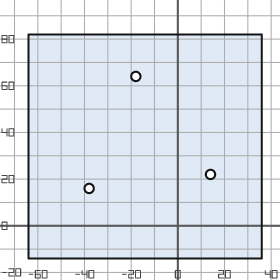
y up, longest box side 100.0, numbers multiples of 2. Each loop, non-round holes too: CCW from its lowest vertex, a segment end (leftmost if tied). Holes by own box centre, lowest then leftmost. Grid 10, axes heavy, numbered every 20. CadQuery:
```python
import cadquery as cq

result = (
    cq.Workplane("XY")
    .moveTo(-64.0, -14.0)
    .lineTo(36.0, -14.0)
    .lineTo(36.0, 82.0)
    .lineTo(-64.0, 82.0)
    .close()
    .moveTo(-38.0, 16.0)
    .circle(2.0)
    .moveTo(14.0, 22.0)
    .circle(2.0)
    .moveTo(-18.0, 64.0)
    .circle(2.0)
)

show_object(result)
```